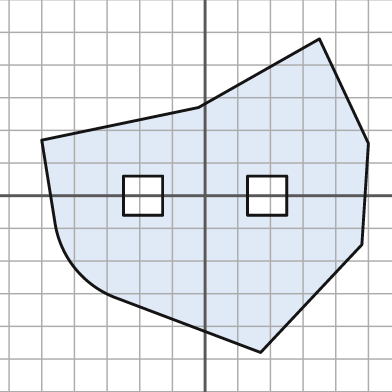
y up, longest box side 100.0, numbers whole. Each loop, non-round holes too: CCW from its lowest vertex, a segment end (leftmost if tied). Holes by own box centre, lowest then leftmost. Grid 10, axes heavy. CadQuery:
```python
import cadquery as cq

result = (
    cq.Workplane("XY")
    .moveTo(17.0, -48.0)
    .lineTo(48.0, -15.0)
    .lineTo(50.0, 16.0)
    .lineTo(35.0, 48.0)
    .lineTo(-2.0, 27.0)
    .lineTo(-50.0, 17.0)
    .lineTo(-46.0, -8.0)
    .threePointArc((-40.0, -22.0), (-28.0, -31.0))
    .close()
    .moveTo(-25.0, -6.0)
    .lineTo(-13.0, -6.0)
    .lineTo(-13.0, 6.0)
    .lineTo(-25.0, 6.0)
    .close()
    .moveTo(13.0, -6.0)
    .lineTo(25.0, -6.0)
    .lineTo(25.0, 6.0)
    .lineTo(13.0, 6.0)
    .close()
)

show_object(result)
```